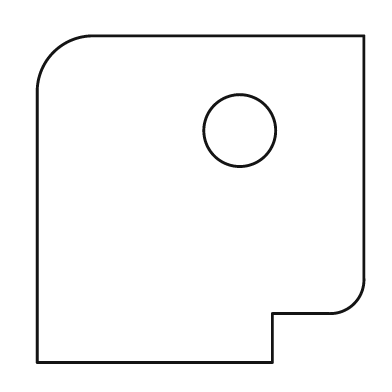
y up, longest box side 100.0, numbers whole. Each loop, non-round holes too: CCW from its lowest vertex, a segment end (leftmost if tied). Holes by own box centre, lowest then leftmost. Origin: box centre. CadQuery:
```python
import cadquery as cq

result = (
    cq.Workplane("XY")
    .moveTo(-50.0, -50.0)
    .lineTo(22.0, -50.0)
    .lineTo(22.0, -35.0)
    .lineTo(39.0, -35.0)
    .threePointArc((47.0, -32.0), (50.0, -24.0))
    .lineTo(50.0, 50.0)
    .lineTo(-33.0, 50.0)
    .threePointArc((-45.0, 45.0), (-50.0, 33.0))
    .close()
    .moveTo(12.0, 21.0)
    .circle(11.0)
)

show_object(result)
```